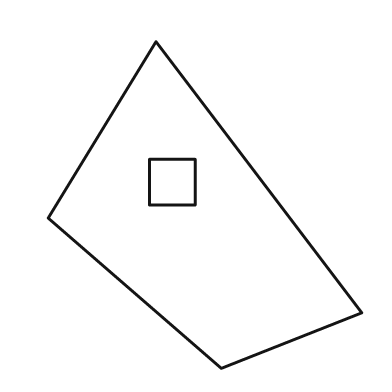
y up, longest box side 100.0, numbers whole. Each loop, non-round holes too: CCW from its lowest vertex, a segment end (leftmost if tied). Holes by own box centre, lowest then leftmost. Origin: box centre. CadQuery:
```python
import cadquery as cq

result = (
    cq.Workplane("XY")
    .moveTo(5.0, -50.0)
    .lineTo(48.0, -33.0)
    .lineTo(-15.0, 50.0)
    .lineTo(-48.0, -4.0)
    .close()
    .moveTo(-17.0, 0.0)
    .lineTo(-3.0, 0.0)
    .lineTo(-3.0, 14.0)
    .lineTo(-17.0, 14.0)
    .close()
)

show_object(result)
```